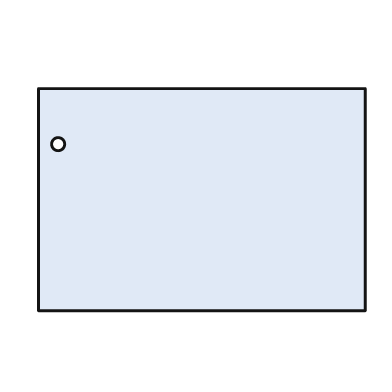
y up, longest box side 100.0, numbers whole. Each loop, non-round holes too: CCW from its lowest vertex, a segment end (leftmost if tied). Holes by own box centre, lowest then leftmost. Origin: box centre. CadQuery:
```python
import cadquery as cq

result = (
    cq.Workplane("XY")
    .moveTo(-50.0, -34.0)
    .lineTo(50.0, -34.0)
    .lineTo(50.0, 34.0)
    .lineTo(-50.0, 34.0)
    .close()
    .moveTo(-44.0, 17.0)
    .circle(2.0)
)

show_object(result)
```